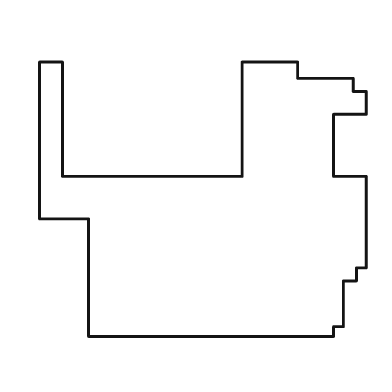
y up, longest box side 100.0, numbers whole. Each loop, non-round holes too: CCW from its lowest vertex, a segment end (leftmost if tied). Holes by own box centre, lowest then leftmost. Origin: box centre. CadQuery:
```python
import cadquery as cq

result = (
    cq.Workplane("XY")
    .moveTo(-35.0, -42.0)
    .lineTo(40.0, -42.0)
    .lineTo(40.0, -39.0)
    .lineTo(43.0, -39.0)
    .lineTo(43.0, -25.0)
    .lineTo(47.0, -25.0)
    .lineTo(47.0, -21.0)
    .lineTo(50.0, -21.0)
    .lineTo(50.0, 7.0)
    .lineTo(40.0, 7.0)
    .lineTo(40.0, 26.0)
    .lineTo(50.0, 26.0)
    .lineTo(50.0, 33.0)
    .lineTo(46.0, 33.0)
    .lineTo(46.0, 37.0)
    .lineTo(29.0, 37.0)
    .lineTo(29.0, 42.0)
    .lineTo(12.0, 42.0)
    .lineTo(12.0, 7.0)
    .lineTo(-43.0, 7.0)
    .lineTo(-43.0, 42.0)
    .lineTo(-50.0, 42.0)
    .lineTo(-50.0, -6.0)
    .lineTo(-35.0, -6.0)
    .close()
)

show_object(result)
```